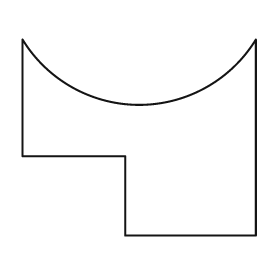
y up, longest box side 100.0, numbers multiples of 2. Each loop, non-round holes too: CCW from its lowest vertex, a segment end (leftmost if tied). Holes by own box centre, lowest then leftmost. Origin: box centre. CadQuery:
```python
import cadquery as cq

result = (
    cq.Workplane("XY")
    .moveTo(-6.0, -42.0)
    .lineTo(50.0, -42.0)
    .lineTo(50.0, 42.0)
    .threePointArc((0.0, 14.0), (-50.0, 42.0))
    .lineTo(-50.0, -8.0)
    .lineTo(-6.0, -8.0)
    .close()
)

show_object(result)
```